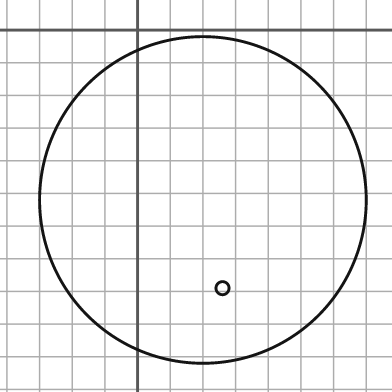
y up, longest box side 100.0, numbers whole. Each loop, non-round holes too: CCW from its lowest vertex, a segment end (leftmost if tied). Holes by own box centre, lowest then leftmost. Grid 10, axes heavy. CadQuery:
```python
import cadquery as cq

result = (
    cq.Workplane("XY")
    .moveTo(20.0, -52.0)
    .circle(50.0)
    .moveTo(26.0, -79.0)
    .circle(2.0)
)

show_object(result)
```